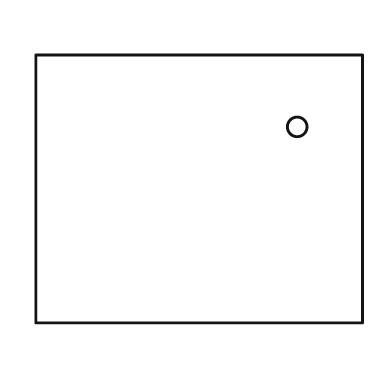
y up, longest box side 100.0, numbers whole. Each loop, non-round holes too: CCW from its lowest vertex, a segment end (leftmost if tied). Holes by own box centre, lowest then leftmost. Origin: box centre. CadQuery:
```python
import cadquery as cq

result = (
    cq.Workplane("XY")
    .moveTo(-50.0, -41.0)
    .lineTo(50.0, -41.0)
    .lineTo(50.0, 41.0)
    .lineTo(-50.0, 41.0)
    .close()
    .moveTo(30.0, 19.0)
    .circle(3.0)
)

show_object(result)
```